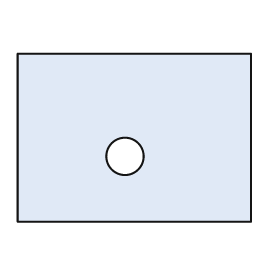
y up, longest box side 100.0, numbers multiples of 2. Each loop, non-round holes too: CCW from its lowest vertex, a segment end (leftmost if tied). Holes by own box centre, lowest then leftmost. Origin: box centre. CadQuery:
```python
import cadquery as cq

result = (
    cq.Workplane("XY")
    .moveTo(-50.0, -36.0)
    .lineTo(50.0, -36.0)
    .lineTo(50.0, 36.0)
    .lineTo(-50.0, 36.0)
    .close()
    .moveTo(-4.0, -8.0)
    .circle(8.0)
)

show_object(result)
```